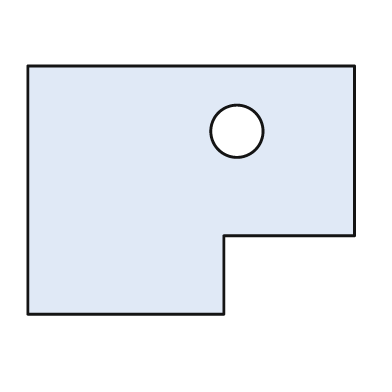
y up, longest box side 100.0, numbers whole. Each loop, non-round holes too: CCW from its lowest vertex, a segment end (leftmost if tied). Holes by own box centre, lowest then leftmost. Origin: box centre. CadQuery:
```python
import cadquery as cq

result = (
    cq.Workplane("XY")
    .moveTo(-50.0, -38.0)
    .lineTo(10.0, -38.0)
    .lineTo(10.0, -14.0)
    .lineTo(50.0, -14.0)
    .lineTo(50.0, 38.0)
    .lineTo(-50.0, 38.0)
    .close()
    .moveTo(14.0, 18.0)
    .circle(8.0)
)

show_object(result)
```